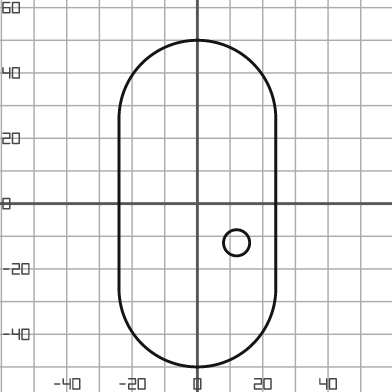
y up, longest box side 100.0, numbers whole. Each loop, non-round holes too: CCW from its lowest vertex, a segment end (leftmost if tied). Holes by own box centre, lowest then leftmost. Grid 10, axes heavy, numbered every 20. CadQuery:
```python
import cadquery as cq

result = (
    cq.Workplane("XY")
    .moveTo(-24.0, -26.0)
    .threePointArc((0.0, -50.0), (24.0, -26.0))
    .lineTo(24.0, 26.0)
    .threePointArc((0.0, 50.0), (-24.0, 26.0))
    .close()
    .moveTo(12.0, -12.0)
    .circle(4.0)
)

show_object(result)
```